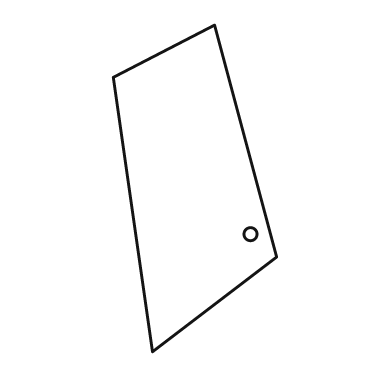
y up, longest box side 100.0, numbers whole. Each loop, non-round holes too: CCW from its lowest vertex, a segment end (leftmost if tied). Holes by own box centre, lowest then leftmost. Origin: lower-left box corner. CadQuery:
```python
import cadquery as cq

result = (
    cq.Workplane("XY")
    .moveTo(12.0, 0.0)
    .lineTo(50.0, 29.0)
    .lineTo(31.0, 100.0)
    .lineTo(0.0, 84.0)
    .close()
    .moveTo(42.0, 36.0)
    .circle(2.0)
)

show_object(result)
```